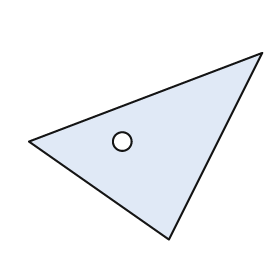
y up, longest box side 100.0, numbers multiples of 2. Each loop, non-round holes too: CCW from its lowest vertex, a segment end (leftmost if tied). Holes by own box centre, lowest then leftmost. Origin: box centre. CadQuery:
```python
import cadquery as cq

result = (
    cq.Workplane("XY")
    .moveTo(10.0, -40.0)
    .lineTo(50.0, 40.0)
    .lineTo(-50.0, 2.0)
    .close()
    .moveTo(-10.0, 2.0)
    .circle(4.0)
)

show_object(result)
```